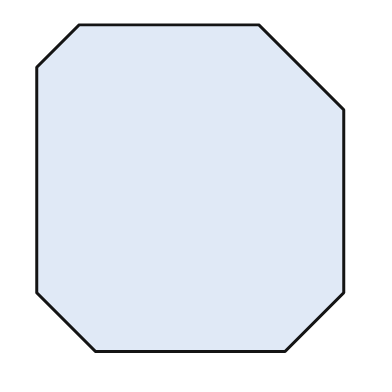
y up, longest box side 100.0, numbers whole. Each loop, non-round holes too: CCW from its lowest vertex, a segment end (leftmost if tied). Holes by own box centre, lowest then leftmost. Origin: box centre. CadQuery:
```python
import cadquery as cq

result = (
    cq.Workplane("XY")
    .moveTo(-29.0, -50.0)
    .lineTo(29.0, -50.0)
    .lineTo(47.0, -32.0)
    .lineTo(47.0, 24.0)
    .lineTo(21.0, 50.0)
    .lineTo(-34.0, 50.0)
    .lineTo(-47.0, 37.0)
    .lineTo(-47.0, -32.0)
    .close()
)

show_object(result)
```